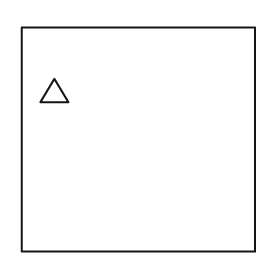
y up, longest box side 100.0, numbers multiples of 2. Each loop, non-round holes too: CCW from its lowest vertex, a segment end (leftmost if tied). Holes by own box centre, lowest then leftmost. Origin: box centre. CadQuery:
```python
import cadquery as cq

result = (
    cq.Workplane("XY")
    .moveTo(-50.0, -48.0)
    .lineTo(50.0, -48.0)
    .lineTo(50.0, 48.0)
    .lineTo(-50.0, 48.0)
    .close()
    .moveTo(-42.0, 16.0)
    .lineTo(-30.0, 16.0)
    .lineTo(-36.0, 26.0)
    .close()
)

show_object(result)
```